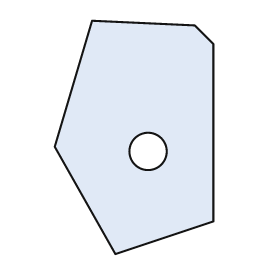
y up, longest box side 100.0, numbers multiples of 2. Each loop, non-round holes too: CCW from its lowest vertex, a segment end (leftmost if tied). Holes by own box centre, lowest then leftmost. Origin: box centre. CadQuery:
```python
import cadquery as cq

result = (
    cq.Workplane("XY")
    .moveTo(-8.0, -50.0)
    .lineTo(34.0, -36.0)
    .lineTo(34.0, 40.0)
    .lineTo(26.0, 48.0)
    .lineTo(-18.0, 50.0)
    .lineTo(-34.0, -4.0)
    .close()
    .moveTo(6.0, -6.0)
    .circle(8.0)
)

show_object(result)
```